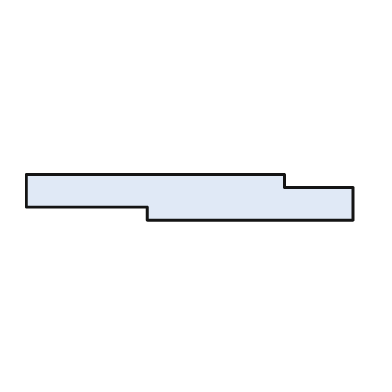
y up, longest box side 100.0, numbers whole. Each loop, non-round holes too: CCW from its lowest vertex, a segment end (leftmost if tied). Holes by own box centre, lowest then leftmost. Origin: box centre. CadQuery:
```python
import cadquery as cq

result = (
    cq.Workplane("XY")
    .moveTo(-13.0, -7.0)
    .lineTo(50.0, -7.0)
    .lineTo(50.0, 3.0)
    .lineTo(29.0, 3.0)
    .lineTo(29.0, 7.0)
    .lineTo(-50.0, 7.0)
    .lineTo(-50.0, -3.0)
    .lineTo(-13.0, -3.0)
    .close()
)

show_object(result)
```